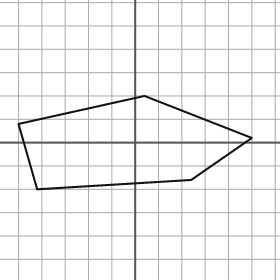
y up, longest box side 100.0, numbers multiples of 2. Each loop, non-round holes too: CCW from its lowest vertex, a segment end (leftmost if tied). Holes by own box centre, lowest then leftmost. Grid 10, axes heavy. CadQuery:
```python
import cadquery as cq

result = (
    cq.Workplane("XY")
    .moveTo(-42.0, -20.0)
    .lineTo(24.0, -16.0)
    .lineTo(50.0, 2.0)
    .lineTo(4.0, 20.0)
    .lineTo(-50.0, 8.0)
    .close()
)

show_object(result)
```